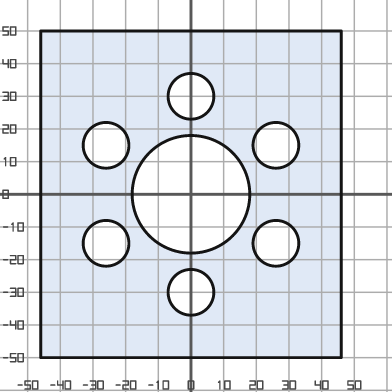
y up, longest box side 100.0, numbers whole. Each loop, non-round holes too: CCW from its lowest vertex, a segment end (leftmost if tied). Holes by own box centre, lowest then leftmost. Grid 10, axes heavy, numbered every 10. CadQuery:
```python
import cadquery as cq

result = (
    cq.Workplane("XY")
    .moveTo(-46.0, -50.0)
    .lineTo(46.0, -50.0)
    .lineTo(46.0, 50.0)
    .lineTo(-46.0, 50.0)
    .close()
    .moveTo(0.0, -30.0)
    .circle(7.0)
    .moveTo(-26.0, -15.0)
    .circle(7.0)
    .moveTo(26.0, -15.0)
    .circle(7.0)
    .moveTo(0.0, 0.0)
    .circle(18.0)
    .moveTo(-26.0, 15.0)
    .circle(7.0)
    .moveTo(26.0, 15.0)
    .circle(7.0)
    .moveTo(0.0, 30.0)
    .circle(7.0)
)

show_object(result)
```